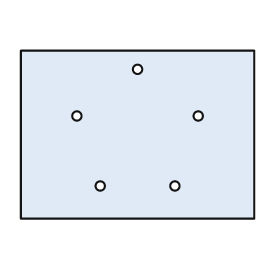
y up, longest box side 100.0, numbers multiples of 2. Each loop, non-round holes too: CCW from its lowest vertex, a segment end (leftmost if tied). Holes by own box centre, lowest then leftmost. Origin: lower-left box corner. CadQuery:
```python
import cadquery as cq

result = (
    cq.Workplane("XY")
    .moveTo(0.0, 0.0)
    .lineTo(100.0, 0.0)
    .lineTo(100.0, 72.0)
    .lineTo(0.0, 72.0)
    .close()
    .moveTo(34.0, 14.0)
    .circle(2.0)
    .moveTo(66.0, 14.0)
    .circle(2.0)
    .moveTo(24.0, 44.0)
    .circle(2.0)
    .moveTo(76.0, 44.0)
    .circle(2.0)
    .moveTo(50.0, 64.0)
    .circle(2.0)
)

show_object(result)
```